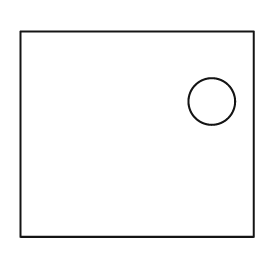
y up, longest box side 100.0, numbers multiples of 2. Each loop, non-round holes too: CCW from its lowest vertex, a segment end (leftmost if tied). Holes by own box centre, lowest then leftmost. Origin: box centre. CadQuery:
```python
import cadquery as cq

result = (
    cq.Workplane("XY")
    .moveTo(-50.0, -44.0)
    .lineTo(50.0, -44.0)
    .lineTo(50.0, 44.0)
    .lineTo(-50.0, 44.0)
    .close()
    .moveTo(32.0, 14.0)
    .circle(10.0)
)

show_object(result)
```